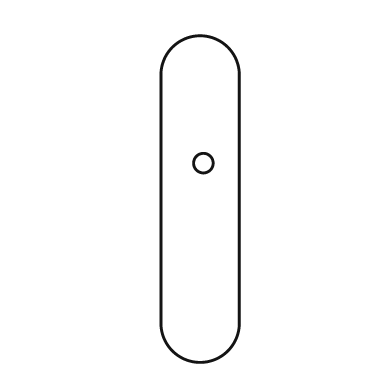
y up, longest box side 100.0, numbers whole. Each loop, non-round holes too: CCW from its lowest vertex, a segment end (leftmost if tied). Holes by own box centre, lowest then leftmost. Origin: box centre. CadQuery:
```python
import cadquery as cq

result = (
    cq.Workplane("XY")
    .moveTo(-12.0, -38.0)
    .threePointArc((0.0, -50.0), (12.0, -38.0))
    .lineTo(12.0, 38.0)
    .threePointArc((0.0, 50.0), (-12.0, 38.0))
    .close()
    .moveTo(1.0, 11.0)
    .circle(3.0)
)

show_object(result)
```